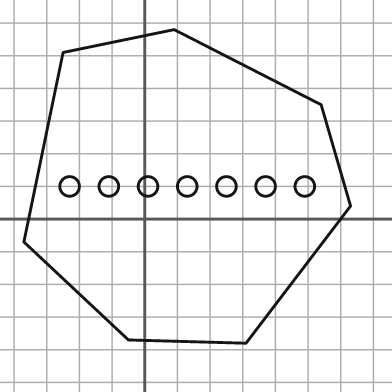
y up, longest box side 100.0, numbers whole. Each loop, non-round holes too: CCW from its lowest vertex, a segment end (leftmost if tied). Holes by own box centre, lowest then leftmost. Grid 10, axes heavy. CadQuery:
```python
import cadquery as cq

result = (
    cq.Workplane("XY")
    .moveTo(31.0, -38.0)
    .lineTo(63.0, 4.0)
    .lineTo(54.0, 35.0)
    .lineTo(9.0, 58.0)
    .lineTo(-25.0, 51.0)
    .lineTo(-37.0, -7.0)
    .lineTo(-5.0, -37.0)
    .close()
    .moveTo(-23.0, 10.0)
    .circle(3.0)
    .moveTo(-11.0, 10.0)
    .circle(3.0)
    .moveTo(1.0, 10.0)
    .circle(3.0)
    .moveTo(13.0, 10.0)
    .circle(3.0)
    .moveTo(25.0, 10.0)
    .circle(3.0)
    .moveTo(37.0, 10.0)
    .circle(3.0)
    .moveTo(49.0, 10.0)
    .circle(3.0)
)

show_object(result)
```